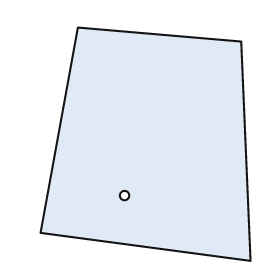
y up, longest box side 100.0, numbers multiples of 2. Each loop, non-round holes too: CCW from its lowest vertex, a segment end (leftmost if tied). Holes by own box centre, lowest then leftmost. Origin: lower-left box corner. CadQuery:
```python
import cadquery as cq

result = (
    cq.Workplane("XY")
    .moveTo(90.0, 0.0)
    .lineTo(86.0, 94.0)
    .lineTo(16.0, 100.0)
    .lineTo(0.0, 12.0)
    .close()
    .moveTo(36.0, 28.0)
    .circle(2.0)
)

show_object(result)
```